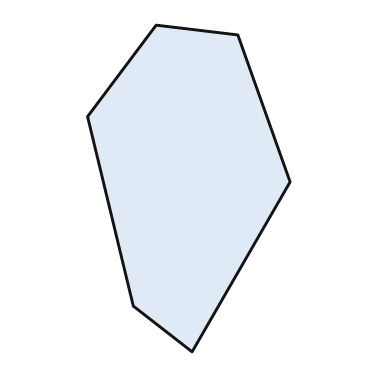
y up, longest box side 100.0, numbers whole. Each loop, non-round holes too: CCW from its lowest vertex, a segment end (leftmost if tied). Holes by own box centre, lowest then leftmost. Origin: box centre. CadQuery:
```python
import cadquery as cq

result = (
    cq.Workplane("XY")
    .moveTo(1.0, -50.0)
    .lineTo(31.0, 2.0)
    .lineTo(15.0, 47.0)
    .lineTo(-10.0, 50.0)
    .lineTo(-31.0, 22.0)
    .lineTo(-17.0, -36.0)
    .close()
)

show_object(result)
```